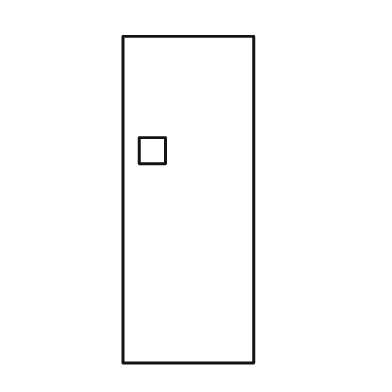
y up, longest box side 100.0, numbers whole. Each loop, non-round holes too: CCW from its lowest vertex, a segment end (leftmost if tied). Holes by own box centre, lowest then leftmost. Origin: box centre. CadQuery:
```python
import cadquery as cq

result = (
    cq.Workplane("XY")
    .moveTo(-20.0, -50.0)
    .lineTo(20.0, -50.0)
    .lineTo(20.0, 50.0)
    .lineTo(-20.0, 50.0)
    .close()
    .moveTo(-15.0, 11.0)
    .lineTo(-7.0, 11.0)
    .lineTo(-7.0, 19.0)
    .lineTo(-15.0, 19.0)
    .close()
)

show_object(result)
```